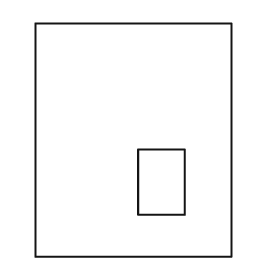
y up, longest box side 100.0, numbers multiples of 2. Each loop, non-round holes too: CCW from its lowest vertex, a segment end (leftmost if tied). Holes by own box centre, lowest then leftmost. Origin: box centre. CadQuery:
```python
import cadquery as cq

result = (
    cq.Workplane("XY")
    .moveTo(-42.0, -50.0)
    .lineTo(42.0, -50.0)
    .lineTo(42.0, 50.0)
    .lineTo(-42.0, 50.0)
    .close()
    .moveTo(2.0, -32.0)
    .lineTo(22.0, -32.0)
    .lineTo(22.0, -4.0)
    .lineTo(2.0, -4.0)
    .close()
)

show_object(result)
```